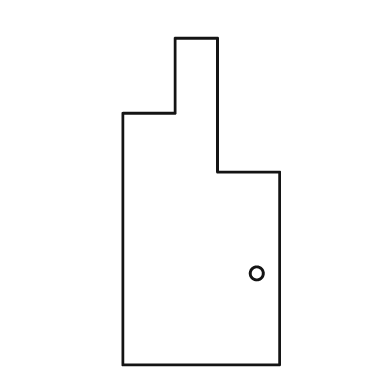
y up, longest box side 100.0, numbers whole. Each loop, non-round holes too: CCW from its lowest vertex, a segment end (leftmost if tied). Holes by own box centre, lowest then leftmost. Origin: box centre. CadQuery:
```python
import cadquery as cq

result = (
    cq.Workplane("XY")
    .moveTo(-24.0, -50.0)
    .lineTo(24.0, -50.0)
    .lineTo(24.0, 9.0)
    .lineTo(5.0, 9.0)
    .lineTo(5.0, 50.0)
    .lineTo(-8.0, 50.0)
    .lineTo(-8.0, 27.0)
    .lineTo(-24.0, 27.0)
    .close()
    .moveTo(17.0, -22.0)
    .circle(2.0)
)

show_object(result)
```